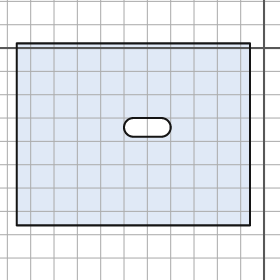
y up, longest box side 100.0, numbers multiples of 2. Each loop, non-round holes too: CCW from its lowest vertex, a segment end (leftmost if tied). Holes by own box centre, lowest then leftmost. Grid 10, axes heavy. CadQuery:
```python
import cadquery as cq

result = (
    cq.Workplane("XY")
    .moveTo(-106.0, -76.0)
    .lineTo(-6.0, -76.0)
    .lineTo(-6.0, 2.0)
    .lineTo(-106.0, 2.0)
    .close()
    .moveTo(-56.0, -38.0)
    .lineTo(-44.0, -38.0)
    .threePointArc((-40.0, -34.0), (-44.0, -30.0))
    .lineTo(-56.0, -30.0)
    .threePointArc((-60.0, -34.0), (-56.0, -38.0))
    .close()
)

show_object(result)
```